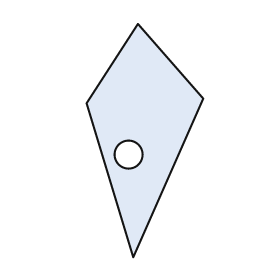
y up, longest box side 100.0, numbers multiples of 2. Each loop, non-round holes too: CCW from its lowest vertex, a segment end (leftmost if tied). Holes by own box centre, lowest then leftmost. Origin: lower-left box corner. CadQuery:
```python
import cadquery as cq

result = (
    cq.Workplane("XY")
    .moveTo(20.0, 0.0)
    .lineTo(50.0, 68.0)
    .lineTo(22.0, 100.0)
    .lineTo(0.0, 66.0)
    .close()
    .moveTo(18.0, 44.0)
    .circle(6.0)
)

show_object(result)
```